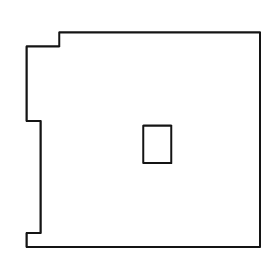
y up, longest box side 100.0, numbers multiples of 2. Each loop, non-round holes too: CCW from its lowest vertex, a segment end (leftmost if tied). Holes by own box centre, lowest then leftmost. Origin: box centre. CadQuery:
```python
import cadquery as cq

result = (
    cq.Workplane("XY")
    .moveTo(-50.0, -46.0)
    .lineTo(50.0, -46.0)
    .lineTo(50.0, 46.0)
    .lineTo(-36.0, 46.0)
    .lineTo(-36.0, 40.0)
    .lineTo(-50.0, 40.0)
    .lineTo(-50.0, 8.0)
    .lineTo(-44.0, 8.0)
    .lineTo(-44.0, -40.0)
    .lineTo(-50.0, -40.0)
    .close()
    .moveTo(0.0, -10.0)
    .lineTo(12.0, -10.0)
    .lineTo(12.0, 6.0)
    .lineTo(0.0, 6.0)
    .close()
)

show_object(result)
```